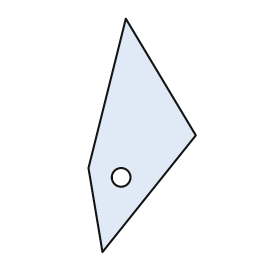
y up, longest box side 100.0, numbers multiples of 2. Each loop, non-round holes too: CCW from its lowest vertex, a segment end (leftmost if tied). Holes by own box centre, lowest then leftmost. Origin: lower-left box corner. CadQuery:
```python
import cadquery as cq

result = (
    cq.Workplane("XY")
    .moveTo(6.0, 0.0)
    .lineTo(46.0, 50.0)
    .lineTo(16.0, 100.0)
    .lineTo(0.0, 36.0)
    .close()
    .moveTo(14.0, 32.0)
    .circle(4.0)
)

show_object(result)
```